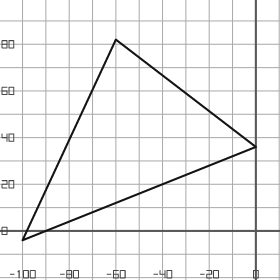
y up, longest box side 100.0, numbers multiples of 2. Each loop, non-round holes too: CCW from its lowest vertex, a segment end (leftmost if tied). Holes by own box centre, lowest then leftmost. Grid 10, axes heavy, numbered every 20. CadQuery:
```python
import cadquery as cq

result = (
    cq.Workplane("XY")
    .moveTo(-100.0, -4.0)
    .lineTo(0.0, 36.0)
    .lineTo(-60.0, 82.0)
    .close()
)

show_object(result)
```